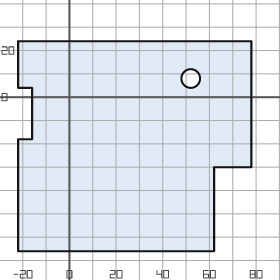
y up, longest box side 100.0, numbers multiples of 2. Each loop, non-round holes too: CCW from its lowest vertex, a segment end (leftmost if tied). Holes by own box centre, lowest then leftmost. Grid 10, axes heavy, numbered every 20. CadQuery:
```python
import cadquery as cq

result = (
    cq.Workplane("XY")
    .moveTo(-22.0, -66.0)
    .lineTo(62.0, -66.0)
    .lineTo(62.0, -30.0)
    .lineTo(78.0, -30.0)
    .lineTo(78.0, 24.0)
    .lineTo(-22.0, 24.0)
    .lineTo(-22.0, 4.0)
    .lineTo(-16.0, 4.0)
    .lineTo(-16.0, -18.0)
    .lineTo(-22.0, -18.0)
    .close()
    .moveTo(52.0, 8.0)
    .circle(4.0)
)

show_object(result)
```